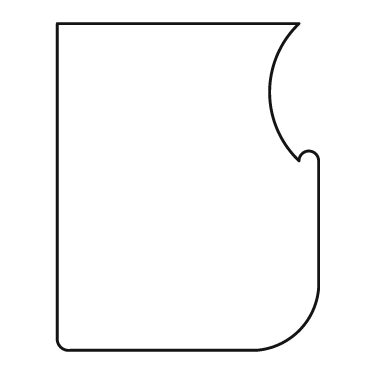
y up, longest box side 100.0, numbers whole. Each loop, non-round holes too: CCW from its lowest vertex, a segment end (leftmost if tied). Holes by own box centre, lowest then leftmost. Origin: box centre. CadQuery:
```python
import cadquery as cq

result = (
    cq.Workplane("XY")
    .moveTo(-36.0, -50.0)
    .lineTo(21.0, -50.0)
    .threePointArc((34.0, -44.0), (40.0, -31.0))
    .lineTo(40.0, 8.0)
    .threePointArc((37.0, 11.0), (34.0, 8.0))
    .threePointArc((25.0, 29.0), (34.0, 50.0))
    .lineTo(-40.0, 50.0)
    .lineTo(-40.0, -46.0)
    .threePointArc((-39.0, -49.0), (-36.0, -50.0))
    .close()
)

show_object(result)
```